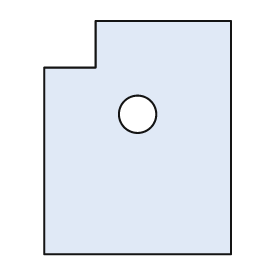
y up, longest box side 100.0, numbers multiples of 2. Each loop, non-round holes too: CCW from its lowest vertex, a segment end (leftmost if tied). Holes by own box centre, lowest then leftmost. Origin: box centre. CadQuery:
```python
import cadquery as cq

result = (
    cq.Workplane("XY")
    .moveTo(-40.0, -50.0)
    .lineTo(40.0, -50.0)
    .lineTo(40.0, 50.0)
    .lineTo(-18.0, 50.0)
    .lineTo(-18.0, 30.0)
    .lineTo(-40.0, 30.0)
    .close()
    .moveTo(0.0, 10.0)
    .circle(8.0)
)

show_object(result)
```